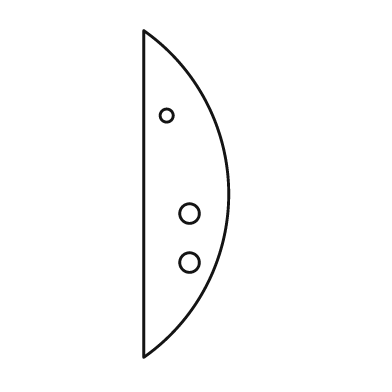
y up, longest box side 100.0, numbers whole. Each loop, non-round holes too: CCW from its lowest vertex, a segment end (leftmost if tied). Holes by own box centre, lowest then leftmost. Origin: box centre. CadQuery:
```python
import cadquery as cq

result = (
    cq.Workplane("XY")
    .moveTo(-13.0, -50.0)
    .threePointArc((13.0, 0.0), (-13.0, 50.0))
    .close()
    .moveTo(1.0, -21.0)
    .circle(3.0)
    .moveTo(1.0, -6.0)
    .circle(3.0)
    .moveTo(-6.0, 24.0)
    .circle(2.0)
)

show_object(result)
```